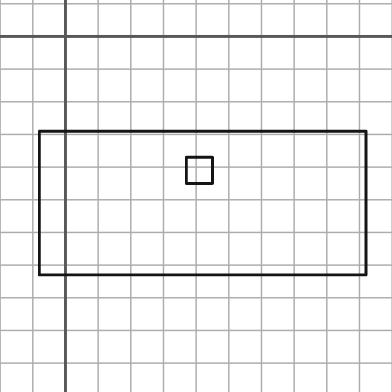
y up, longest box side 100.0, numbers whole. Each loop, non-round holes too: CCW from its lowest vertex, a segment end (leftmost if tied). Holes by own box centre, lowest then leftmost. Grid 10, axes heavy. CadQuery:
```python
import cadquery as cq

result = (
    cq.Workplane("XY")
    .moveTo(-8.0, -73.0)
    .lineTo(92.0, -73.0)
    .lineTo(92.0, -29.0)
    .lineTo(-8.0, -29.0)
    .close()
    .moveTo(37.0, -45.0)
    .lineTo(45.0, -45.0)
    .lineTo(45.0, -37.0)
    .lineTo(37.0, -37.0)
    .close()
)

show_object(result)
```